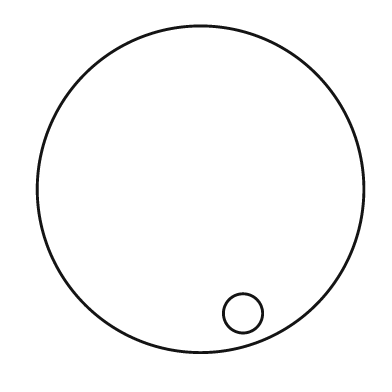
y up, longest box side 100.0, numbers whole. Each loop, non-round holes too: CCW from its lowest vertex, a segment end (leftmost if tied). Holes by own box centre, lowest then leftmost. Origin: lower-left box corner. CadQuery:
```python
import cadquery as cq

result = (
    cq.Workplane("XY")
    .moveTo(50.0, 50.0)
    .circle(50.0)
    .moveTo(63.0, 12.0)
    .circle(6.0)
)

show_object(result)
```